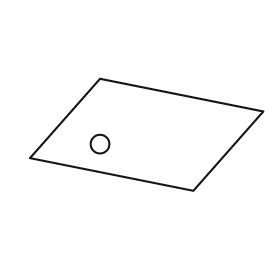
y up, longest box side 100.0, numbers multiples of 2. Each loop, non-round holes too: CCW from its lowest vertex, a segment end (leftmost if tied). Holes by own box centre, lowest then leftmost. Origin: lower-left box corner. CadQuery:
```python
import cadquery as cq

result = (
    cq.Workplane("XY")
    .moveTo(70.0, 0.0)
    .lineTo(100.0, 34.0)
    .lineTo(30.0, 48.0)
    .lineTo(0.0, 14.0)
    .close()
    .moveTo(30.0, 20.0)
    .circle(4.0)
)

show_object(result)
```